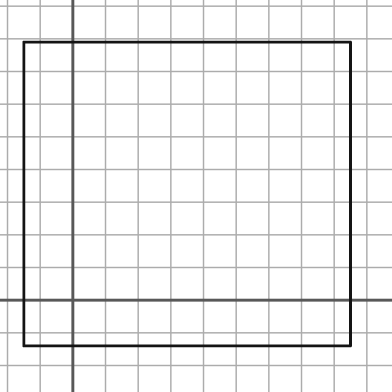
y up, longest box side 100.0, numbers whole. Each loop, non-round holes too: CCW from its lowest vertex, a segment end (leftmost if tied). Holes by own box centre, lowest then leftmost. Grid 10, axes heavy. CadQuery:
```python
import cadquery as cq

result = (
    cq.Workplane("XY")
    .moveTo(-15.0, -14.0)
    .lineTo(85.0, -14.0)
    .lineTo(85.0, 79.0)
    .lineTo(-15.0, 79.0)
    .close()
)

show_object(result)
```